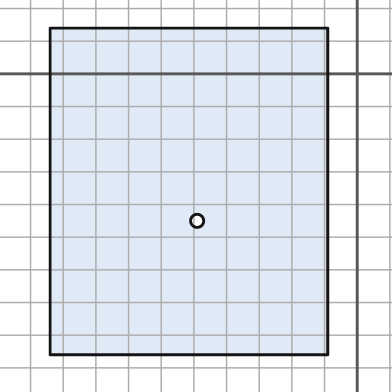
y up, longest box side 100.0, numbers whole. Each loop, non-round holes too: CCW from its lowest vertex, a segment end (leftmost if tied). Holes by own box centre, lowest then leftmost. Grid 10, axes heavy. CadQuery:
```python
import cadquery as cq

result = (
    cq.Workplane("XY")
    .moveTo(-94.0, -86.0)
    .lineTo(-9.0, -86.0)
    .lineTo(-9.0, 14.0)
    .lineTo(-94.0, 14.0)
    .close()
    .moveTo(-49.0, -45.0)
    .circle(2.0)
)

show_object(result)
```